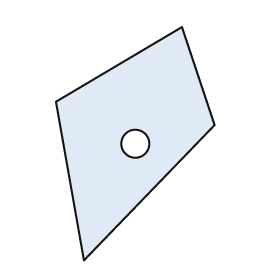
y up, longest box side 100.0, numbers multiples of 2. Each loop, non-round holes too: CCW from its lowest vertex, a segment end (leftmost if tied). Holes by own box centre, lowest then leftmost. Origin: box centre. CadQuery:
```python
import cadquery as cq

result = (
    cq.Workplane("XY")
    .moveTo(-22.0, -50.0)
    .lineTo(34.0, 8.0)
    .lineTo(20.0, 50.0)
    .lineTo(-34.0, 18.0)
    .close()
    .moveTo(0.0, 0.0)
    .circle(6.0)
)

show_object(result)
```